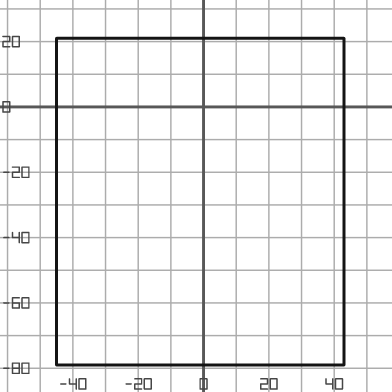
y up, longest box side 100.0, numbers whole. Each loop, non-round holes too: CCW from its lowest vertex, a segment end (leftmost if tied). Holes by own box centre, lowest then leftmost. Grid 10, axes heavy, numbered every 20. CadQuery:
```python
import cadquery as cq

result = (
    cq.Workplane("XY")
    .moveTo(-45.0, -79.0)
    .lineTo(43.0, -79.0)
    .lineTo(43.0, 21.0)
    .lineTo(-45.0, 21.0)
    .close()
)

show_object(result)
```